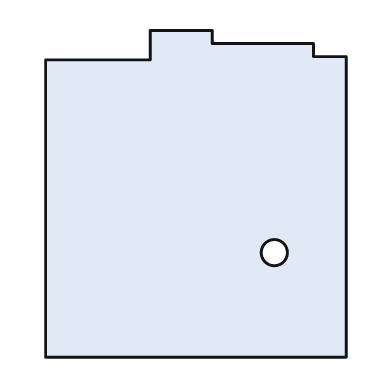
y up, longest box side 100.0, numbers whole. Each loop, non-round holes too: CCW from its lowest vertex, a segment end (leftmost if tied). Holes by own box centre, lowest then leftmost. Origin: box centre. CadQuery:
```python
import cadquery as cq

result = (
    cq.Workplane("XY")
    .moveTo(-46.0, -50.0)
    .lineTo(46.0, -50.0)
    .lineTo(46.0, 42.0)
    .lineTo(36.0, 42.0)
    .lineTo(36.0, 46.0)
    .lineTo(5.0, 46.0)
    .lineTo(5.0, 50.0)
    .lineTo(-14.0, 50.0)
    .lineTo(-14.0, 41.0)
    .lineTo(-46.0, 41.0)
    .close()
    .moveTo(24.0, -18.0)
    .circle(4.0)
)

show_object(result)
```